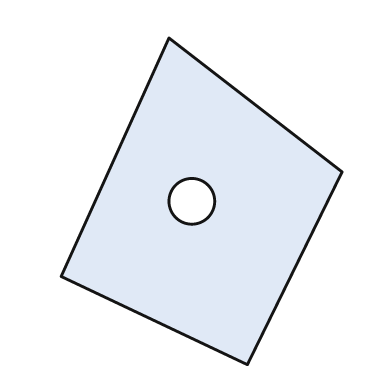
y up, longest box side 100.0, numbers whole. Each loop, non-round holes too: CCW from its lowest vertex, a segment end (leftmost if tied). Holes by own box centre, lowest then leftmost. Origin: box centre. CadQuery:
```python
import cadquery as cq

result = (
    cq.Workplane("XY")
    .moveTo(14.0, -50.0)
    .lineTo(43.0, 9.0)
    .lineTo(-10.0, 50.0)
    .lineTo(-43.0, -23.0)
    .close()
    .moveTo(-3.0, 0.0)
    .circle(7.0)
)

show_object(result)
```